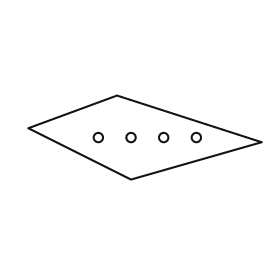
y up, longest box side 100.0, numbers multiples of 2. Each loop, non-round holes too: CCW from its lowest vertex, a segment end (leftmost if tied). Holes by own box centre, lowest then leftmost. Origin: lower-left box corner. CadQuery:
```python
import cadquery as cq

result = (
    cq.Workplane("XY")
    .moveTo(44.0, 0.0)
    .lineTo(100.0, 16.0)
    .lineTo(38.0, 36.0)
    .lineTo(0.0, 22.0)
    .close()
    .moveTo(30.0, 18.0)
    .circle(2.0)
    .moveTo(44.0, 18.0)
    .circle(2.0)
    .moveTo(58.0, 18.0)
    .circle(2.0)
    .moveTo(72.0, 18.0)
    .circle(2.0)
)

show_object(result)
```